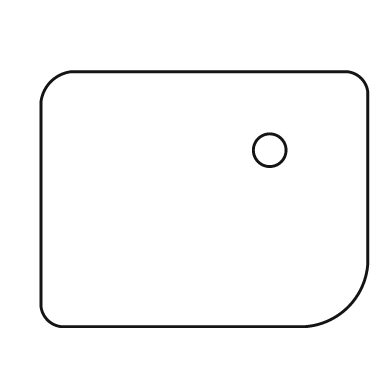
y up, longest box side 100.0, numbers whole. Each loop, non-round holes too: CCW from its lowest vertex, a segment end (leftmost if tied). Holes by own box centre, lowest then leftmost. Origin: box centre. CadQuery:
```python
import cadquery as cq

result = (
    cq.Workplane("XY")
    .moveTo(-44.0, -39.0)
    .lineTo(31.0, -39.0)
    .threePointArc((44.0, -33.0), (50.0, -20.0))
    .lineTo(50.0, 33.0)
    .threePointArc((48.0, 37.0), (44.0, 39.0))
    .lineTo(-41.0, 39.0)
    .threePointArc((-47.0, 36.0), (-50.0, 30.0))
    .lineTo(-50.0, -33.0)
    .threePointArc((-48.0, -37.0), (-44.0, -39.0))
    .close()
    .moveTo(20.0, 15.0)
    .circle(5.0)
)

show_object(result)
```